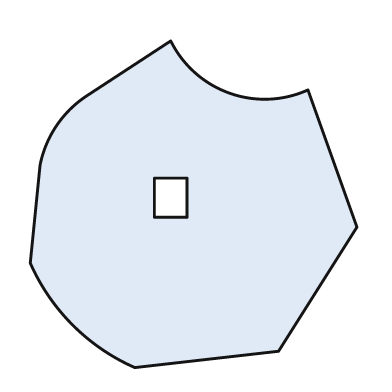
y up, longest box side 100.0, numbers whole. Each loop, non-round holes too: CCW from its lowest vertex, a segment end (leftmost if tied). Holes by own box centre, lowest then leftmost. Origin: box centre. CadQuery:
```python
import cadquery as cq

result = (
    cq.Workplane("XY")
    .moveTo(-18.0, -50.0)
    .lineTo(26.0, -45.0)
    .lineTo(50.0, -7.0)
    .lineTo(35.0, 35.0)
    .threePointArc((11.0, 34.0), (-7.0, 50.0))
    .lineTo(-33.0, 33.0)
    .threePointArc((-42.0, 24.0), (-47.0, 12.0))
    .lineTo(-50.0, -18.0)
    .threePointArc((-37.0, -37.0), (-18.0, -50.0))
    .close()
    .moveTo(-12.0, -4.0)
    .lineTo(-2.0, -4.0)
    .lineTo(-2.0, 8.0)
    .lineTo(-12.0, 8.0)
    .close()
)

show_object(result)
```